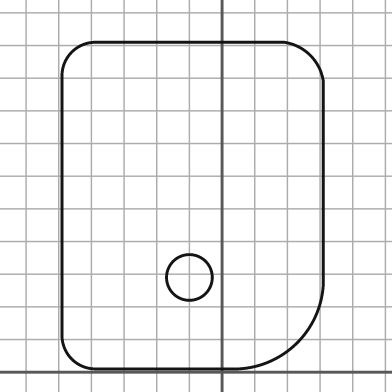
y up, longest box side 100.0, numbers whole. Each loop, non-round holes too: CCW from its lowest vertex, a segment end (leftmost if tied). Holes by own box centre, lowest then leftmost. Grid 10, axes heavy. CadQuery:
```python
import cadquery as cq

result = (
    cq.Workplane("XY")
    .moveTo(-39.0, 1.0)
    .lineTo(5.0, 1.0)
    .threePointArc((23.0, 9.0), (31.0, 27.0))
    .lineTo(31.0, 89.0)
    .threePointArc((27.0, 97.0), (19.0, 101.0))
    .lineTo(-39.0, 101.0)
    .threePointArc((-46.0, 98.0), (-49.0, 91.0))
    .lineTo(-49.0, 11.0)
    .threePointArc((-46.0, 4.0), (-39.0, 1.0))
    .close()
    .moveTo(-10.0, 29.0)
    .circle(7.0)
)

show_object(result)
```